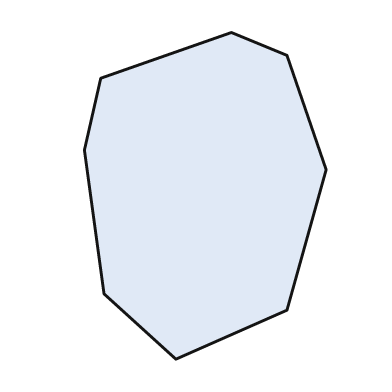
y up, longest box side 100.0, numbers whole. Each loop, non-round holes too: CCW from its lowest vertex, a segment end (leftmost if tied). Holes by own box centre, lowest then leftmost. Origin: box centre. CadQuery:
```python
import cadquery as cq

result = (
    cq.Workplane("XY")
    .moveTo(-9.0, -50.0)
    .lineTo(25.0, -35.0)
    .lineTo(37.0, 8.0)
    .lineTo(25.0, 43.0)
    .lineTo(8.0, 50.0)
    .lineTo(-32.0, 36.0)
    .lineTo(-37.0, 14.0)
    .lineTo(-31.0, -30.0)
    .close()
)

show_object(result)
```